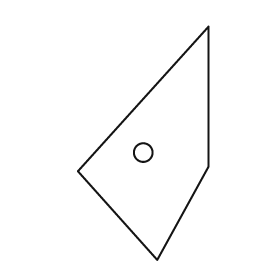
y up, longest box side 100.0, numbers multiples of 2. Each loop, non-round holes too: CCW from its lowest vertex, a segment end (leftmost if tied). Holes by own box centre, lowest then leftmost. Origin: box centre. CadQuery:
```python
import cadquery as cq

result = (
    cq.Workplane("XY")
    .moveTo(6.0, -50.0)
    .lineTo(28.0, -10.0)
    .lineTo(28.0, 50.0)
    .lineTo(-28.0, -12.0)
    .close()
    .moveTo(0.0, -4.0)
    .circle(4.0)
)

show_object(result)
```